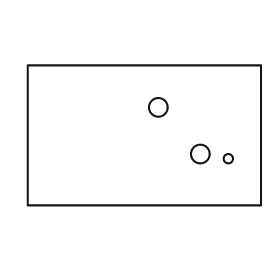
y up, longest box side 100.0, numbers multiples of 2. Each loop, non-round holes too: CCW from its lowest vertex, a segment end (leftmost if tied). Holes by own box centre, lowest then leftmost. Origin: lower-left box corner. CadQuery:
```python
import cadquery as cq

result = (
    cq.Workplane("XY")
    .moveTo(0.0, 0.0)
    .lineTo(100.0, 0.0)
    .lineTo(100.0, 60.0)
    .lineTo(0.0, 60.0)
    .close()
    .moveTo(86.0, 20.0)
    .circle(2.0)
    .moveTo(74.0, 22.0)
    .circle(4.0)
    .moveTo(56.0, 42.0)
    .circle(4.0)
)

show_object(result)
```